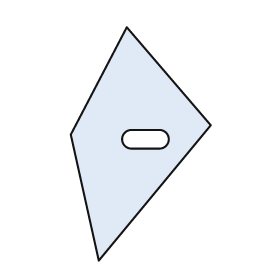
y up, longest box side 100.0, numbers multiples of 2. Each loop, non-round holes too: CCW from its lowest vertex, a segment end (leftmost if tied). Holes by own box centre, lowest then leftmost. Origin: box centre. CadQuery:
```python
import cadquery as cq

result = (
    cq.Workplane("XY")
    .moveTo(-18.0, -50.0)
    .lineTo(30.0, 8.0)
    .lineTo(-6.0, 50.0)
    .lineTo(-30.0, 4.0)
    .close()
    .moveTo(-4.0, -2.0)
    .lineTo(8.0, -2.0)
    .threePointArc((12.0, 2.0), (8.0, 6.0))
    .lineTo(-4.0, 6.0)
    .threePointArc((-8.0, 2.0), (-4.0, -2.0))
    .close()
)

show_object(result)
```